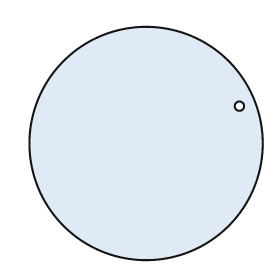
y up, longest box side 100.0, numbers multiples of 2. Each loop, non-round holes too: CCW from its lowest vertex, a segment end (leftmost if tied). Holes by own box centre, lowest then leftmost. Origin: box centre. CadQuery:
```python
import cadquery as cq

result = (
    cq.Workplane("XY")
    .moveTo(0.0, 0.0)
    .circle(50.0)
    .moveTo(40.0, 16.0)
    .circle(2.0)
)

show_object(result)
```